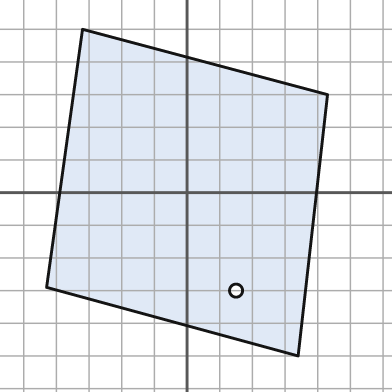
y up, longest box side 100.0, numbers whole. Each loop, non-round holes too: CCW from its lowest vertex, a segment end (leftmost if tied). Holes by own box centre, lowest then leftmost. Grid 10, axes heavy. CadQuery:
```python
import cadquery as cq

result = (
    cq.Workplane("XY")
    .moveTo(34.0, -50.0)
    .lineTo(43.0, 30.0)
    .lineTo(-32.0, 50.0)
    .lineTo(-43.0, -29.0)
    .close()
    .moveTo(15.0, -30.0)
    .circle(2.0)
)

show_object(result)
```